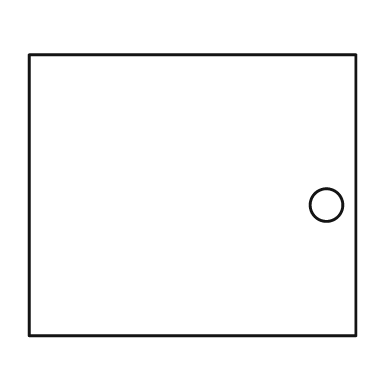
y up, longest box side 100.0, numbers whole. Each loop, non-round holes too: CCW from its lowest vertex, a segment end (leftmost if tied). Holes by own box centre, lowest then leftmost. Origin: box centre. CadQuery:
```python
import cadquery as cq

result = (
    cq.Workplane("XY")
    .moveTo(-50.0, -43.0)
    .lineTo(50.0, -43.0)
    .lineTo(50.0, 43.0)
    .lineTo(-50.0, 43.0)
    .close()
    .moveTo(41.0, -3.0)
    .circle(5.0)
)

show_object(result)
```